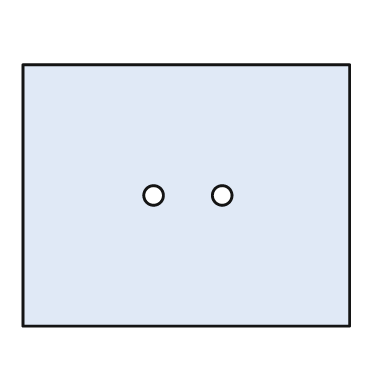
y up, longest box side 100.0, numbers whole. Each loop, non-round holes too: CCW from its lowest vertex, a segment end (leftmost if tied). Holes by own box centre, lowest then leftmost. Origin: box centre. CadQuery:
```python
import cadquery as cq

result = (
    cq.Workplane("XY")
    .moveTo(-50.0, -40.0)
    .lineTo(50.0, -40.0)
    .lineTo(50.0, 40.0)
    .lineTo(-50.0, 40.0)
    .close()
    .moveTo(-10.0, 0.0)
    .circle(3.0)
    .moveTo(11.0, 0.0)
    .circle(3.0)
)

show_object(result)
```